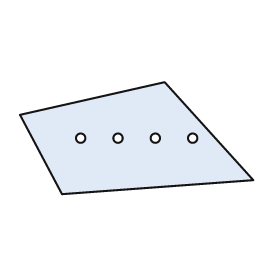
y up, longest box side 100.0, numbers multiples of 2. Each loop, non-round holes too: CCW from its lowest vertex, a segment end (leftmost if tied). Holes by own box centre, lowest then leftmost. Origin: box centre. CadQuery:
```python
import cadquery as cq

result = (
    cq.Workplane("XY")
    .moveTo(-32.0, -24.0)
    .lineTo(50.0, -18.0)
    .lineTo(12.0, 24.0)
    .lineTo(-50.0, 10.0)
    .close()
    .moveTo(-24.0, 0.0)
    .circle(2.0)
    .moveTo(-8.0, 0.0)
    .circle(2.0)
    .moveTo(8.0, 0.0)
    .circle(2.0)
    .moveTo(24.0, 0.0)
    .circle(2.0)
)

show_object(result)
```